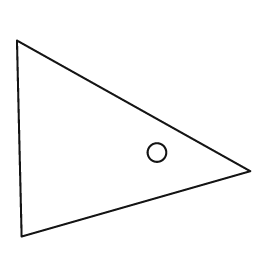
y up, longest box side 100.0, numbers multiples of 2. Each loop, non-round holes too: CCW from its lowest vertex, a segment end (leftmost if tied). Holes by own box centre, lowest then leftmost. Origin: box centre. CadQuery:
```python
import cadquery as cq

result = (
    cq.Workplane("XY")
    .moveTo(-48.0, -42.0)
    .lineTo(50.0, -14.0)
    .lineTo(-50.0, 42.0)
    .close()
    .moveTo(10.0, -6.0)
    .circle(4.0)
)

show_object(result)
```